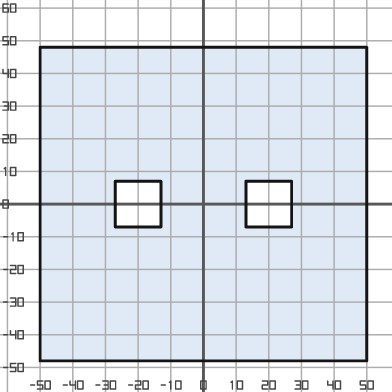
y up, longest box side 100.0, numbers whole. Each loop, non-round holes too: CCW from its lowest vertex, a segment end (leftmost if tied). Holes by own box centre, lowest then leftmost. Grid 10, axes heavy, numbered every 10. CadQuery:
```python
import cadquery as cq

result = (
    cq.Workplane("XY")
    .moveTo(-50.0, -48.0)
    .lineTo(50.0, -48.0)
    .lineTo(50.0, 48.0)
    .lineTo(-50.0, 48.0)
    .close()
    .moveTo(-27.0, -7.0)
    .lineTo(-13.0, -7.0)
    .lineTo(-13.0, 7.0)
    .lineTo(-27.0, 7.0)
    .close()
    .moveTo(13.0, -7.0)
    .lineTo(27.0, -7.0)
    .lineTo(27.0, 7.0)
    .lineTo(13.0, 7.0)
    .close()
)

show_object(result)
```